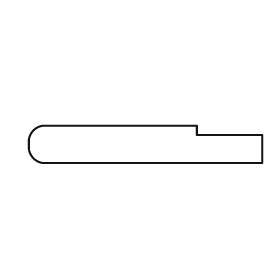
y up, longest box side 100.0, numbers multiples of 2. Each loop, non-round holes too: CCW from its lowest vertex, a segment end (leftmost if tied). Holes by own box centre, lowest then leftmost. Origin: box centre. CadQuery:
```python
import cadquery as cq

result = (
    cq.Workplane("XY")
    .moveTo(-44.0, -8.0)
    .lineTo(50.0, -8.0)
    .lineTo(50.0, 4.0)
    .lineTo(22.0, 4.0)
    .lineTo(22.0, 8.0)
    .lineTo(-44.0, 8.0)
    .threePointArc((-48.0, 6.0), (-50.0, 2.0))
    .lineTo(-50.0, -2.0)
    .threePointArc((-48.0, -6.0), (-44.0, -8.0))
    .close()
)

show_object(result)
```